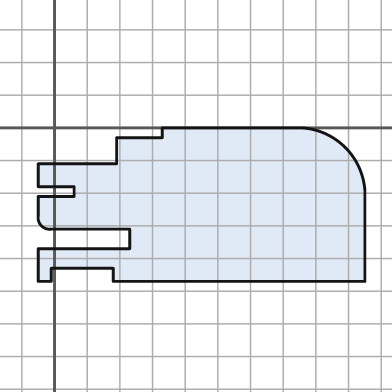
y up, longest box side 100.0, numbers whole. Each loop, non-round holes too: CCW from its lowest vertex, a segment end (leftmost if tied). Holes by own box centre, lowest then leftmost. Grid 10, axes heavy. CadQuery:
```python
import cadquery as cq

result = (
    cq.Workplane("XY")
    .moveTo(-5.0, -47.0)
    .lineTo(-1.0, -47.0)
    .lineTo(-1.0, -43.0)
    .lineTo(18.0, -43.0)
    .lineTo(18.0, -47.0)
    .lineTo(95.0, -47.0)
    .lineTo(95.0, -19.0)
    .threePointArc((89.0, -6.0), (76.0, 0.0))
    .lineTo(33.0, 0.0)
    .lineTo(33.0, -3.0)
    .lineTo(19.0, -3.0)
    .lineTo(19.0, -11.0)
    .lineTo(-5.0, -11.0)
    .lineTo(-5.0, -18.0)
    .lineTo(6.0, -18.0)
    .lineTo(6.0, -21.0)
    .lineTo(-5.0, -21.0)
    .lineTo(-5.0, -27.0)
    .threePointArc((-4.0, -30.0), (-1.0, -31.0))
    .lineTo(23.0, -31.0)
    .lineTo(23.0, -37.0)
    .lineTo(-5.0, -37.0)
    .close()
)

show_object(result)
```